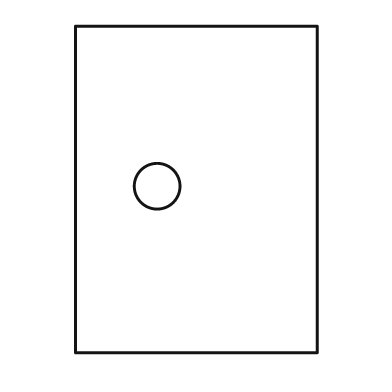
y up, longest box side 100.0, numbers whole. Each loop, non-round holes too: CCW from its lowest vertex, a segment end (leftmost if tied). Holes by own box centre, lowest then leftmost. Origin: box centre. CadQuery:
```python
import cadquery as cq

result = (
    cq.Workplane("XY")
    .moveTo(-37.0, -50.0)
    .lineTo(37.0, -50.0)
    .lineTo(37.0, 50.0)
    .lineTo(-37.0, 50.0)
    .close()
    .moveTo(-12.0, 1.0)
    .circle(7.0)
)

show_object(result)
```